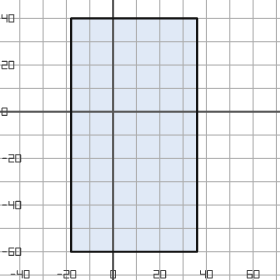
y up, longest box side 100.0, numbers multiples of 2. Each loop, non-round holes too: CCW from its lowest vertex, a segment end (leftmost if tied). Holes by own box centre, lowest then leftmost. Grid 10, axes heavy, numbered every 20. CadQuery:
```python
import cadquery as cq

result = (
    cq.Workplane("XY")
    .moveTo(-18.0, -60.0)
    .lineTo(36.0, -60.0)
    .lineTo(36.0, 40.0)
    .lineTo(-18.0, 40.0)
    .close()
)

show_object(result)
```